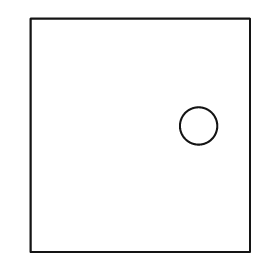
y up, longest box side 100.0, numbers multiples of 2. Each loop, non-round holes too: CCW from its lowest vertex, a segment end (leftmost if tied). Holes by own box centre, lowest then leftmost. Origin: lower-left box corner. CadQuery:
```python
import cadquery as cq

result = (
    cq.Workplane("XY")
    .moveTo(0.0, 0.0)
    .lineTo(94.0, 0.0)
    .lineTo(94.0, 100.0)
    .lineTo(0.0, 100.0)
    .close()
    .moveTo(72.0, 54.0)
    .circle(8.0)
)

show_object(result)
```